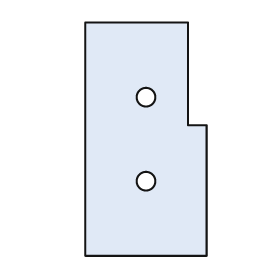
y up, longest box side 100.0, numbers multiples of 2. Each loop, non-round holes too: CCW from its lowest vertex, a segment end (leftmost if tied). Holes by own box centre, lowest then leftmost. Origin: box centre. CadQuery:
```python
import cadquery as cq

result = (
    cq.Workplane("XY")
    .moveTo(-26.0, -50.0)
    .lineTo(26.0, -50.0)
    .lineTo(26.0, 6.0)
    .lineTo(18.0, 6.0)
    .lineTo(18.0, 50.0)
    .lineTo(-26.0, 50.0)
    .close()
    .moveTo(0.0, -18.0)
    .circle(4.0)
    .moveTo(0.0, 18.0)
    .circle(4.0)
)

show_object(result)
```